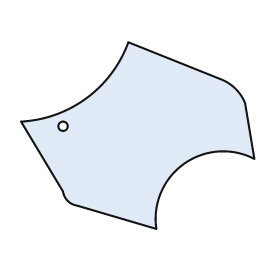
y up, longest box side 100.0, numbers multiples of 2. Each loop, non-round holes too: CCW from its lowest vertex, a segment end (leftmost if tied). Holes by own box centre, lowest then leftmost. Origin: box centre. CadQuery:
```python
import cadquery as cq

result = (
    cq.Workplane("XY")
    .moveTo(8.0, -40.0)
    .threePointArc((20.0, -12.0), (50.0, -10.0))
    .lineTo(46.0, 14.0)
    .threePointArc((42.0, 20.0), (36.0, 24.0))
    .lineTo(-4.0, 40.0)
    .threePointArc((-22.0, 16.0), (-50.0, 6.0))
    .lineTo(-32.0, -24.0)
    .threePointArc((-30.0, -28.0), (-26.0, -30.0))
    .close()
    .moveTo(-32.0, 4.0)
    .circle(2.0)
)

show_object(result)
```